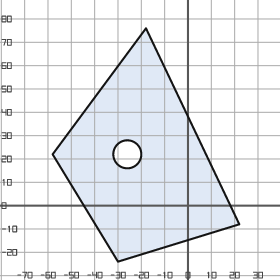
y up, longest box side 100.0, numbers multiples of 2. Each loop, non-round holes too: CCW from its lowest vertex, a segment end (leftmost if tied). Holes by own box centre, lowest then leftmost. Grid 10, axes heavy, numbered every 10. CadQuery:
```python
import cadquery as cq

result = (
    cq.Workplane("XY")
    .moveTo(-30.0, -24.0)
    .lineTo(22.0, -8.0)
    .lineTo(-18.0, 76.0)
    .lineTo(-58.0, 22.0)
    .close()
    .moveTo(-26.0, 22.0)
    .circle(6.0)
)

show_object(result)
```